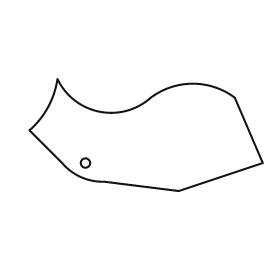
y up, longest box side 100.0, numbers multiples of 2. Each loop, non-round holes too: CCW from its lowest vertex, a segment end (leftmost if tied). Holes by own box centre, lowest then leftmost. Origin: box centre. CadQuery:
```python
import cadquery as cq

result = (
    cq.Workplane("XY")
    .moveTo(14.0, -24.0)
    .lineTo(50.0, -12.0)
    .lineTo(38.0, 16.0)
    .threePointArc((20.0, 22.0), (2.0, 16.0))
    .threePointArc((-20.0, 10.0), (-38.0, 24.0))
    .threePointArc((-42.0, 12.0), (-50.0, 2.0))
    .lineTo(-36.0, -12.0)
    .threePointArc((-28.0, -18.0), (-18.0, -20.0))
    .close()
    .moveTo(-26.0, -12.0)
    .circle(2.0)
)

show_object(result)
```